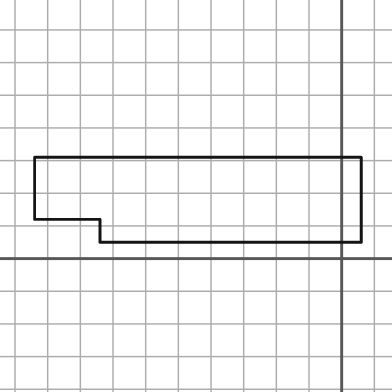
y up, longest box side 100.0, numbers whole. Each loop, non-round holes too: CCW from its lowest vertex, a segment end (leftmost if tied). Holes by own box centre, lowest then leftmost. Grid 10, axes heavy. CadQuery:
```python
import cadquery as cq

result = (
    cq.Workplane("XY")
    .moveTo(-74.0, 5.0)
    .lineTo(6.0, 5.0)
    .lineTo(6.0, 31.0)
    .lineTo(-94.0, 31.0)
    .lineTo(-94.0, 12.0)
    .lineTo(-74.0, 12.0)
    .close()
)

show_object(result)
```